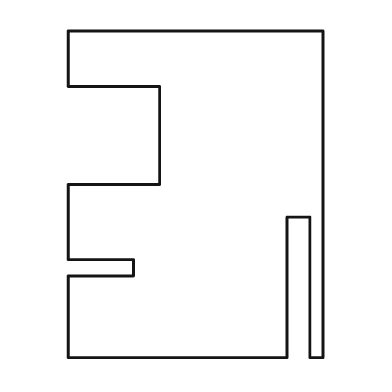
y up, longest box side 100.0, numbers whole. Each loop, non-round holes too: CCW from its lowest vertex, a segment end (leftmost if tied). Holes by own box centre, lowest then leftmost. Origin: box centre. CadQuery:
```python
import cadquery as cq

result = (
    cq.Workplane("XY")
    .moveTo(-39.0, -50.0)
    .lineTo(28.0, -50.0)
    .lineTo(28.0, -7.0)
    .lineTo(35.0, -7.0)
    .lineTo(35.0, -50.0)
    .lineTo(39.0, -50.0)
    .lineTo(39.0, 50.0)
    .lineTo(-39.0, 50.0)
    .lineTo(-39.0, 33.0)
    .lineTo(-11.0, 33.0)
    .lineTo(-11.0, 3.0)
    .lineTo(-39.0, 3.0)
    .lineTo(-39.0, -20.0)
    .lineTo(-19.0, -20.0)
    .lineTo(-19.0, -25.0)
    .lineTo(-39.0, -25.0)
    .close()
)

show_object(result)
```